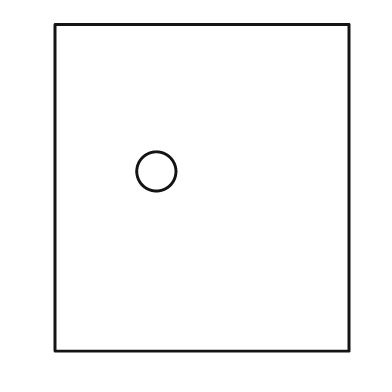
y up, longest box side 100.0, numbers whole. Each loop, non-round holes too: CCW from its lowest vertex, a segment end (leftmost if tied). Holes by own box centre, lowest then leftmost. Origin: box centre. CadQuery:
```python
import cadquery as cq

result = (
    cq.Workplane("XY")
    .moveTo(-45.0, -50.0)
    .lineTo(45.0, -50.0)
    .lineTo(45.0, 50.0)
    .lineTo(-45.0, 50.0)
    .close()
    .moveTo(-14.0, 5.0)
    .circle(6.0)
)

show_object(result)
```